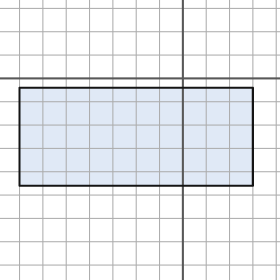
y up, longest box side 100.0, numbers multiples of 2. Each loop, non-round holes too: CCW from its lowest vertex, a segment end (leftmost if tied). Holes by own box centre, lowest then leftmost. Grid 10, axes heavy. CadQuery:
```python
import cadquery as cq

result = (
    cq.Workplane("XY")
    .moveTo(-70.0, -46.0)
    .lineTo(30.0, -46.0)
    .lineTo(30.0, -4.0)
    .lineTo(-70.0, -4.0)
    .close()
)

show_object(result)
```